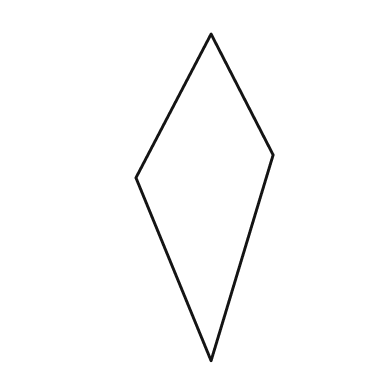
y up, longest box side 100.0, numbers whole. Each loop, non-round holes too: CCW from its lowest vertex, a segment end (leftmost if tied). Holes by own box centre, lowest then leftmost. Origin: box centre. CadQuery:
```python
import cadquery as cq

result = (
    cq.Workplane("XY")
    .moveTo(2.0, -50.0)
    .lineTo(21.0, 13.0)
    .lineTo(2.0, 50.0)
    .lineTo(-21.0, 6.0)
    .close()
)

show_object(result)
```